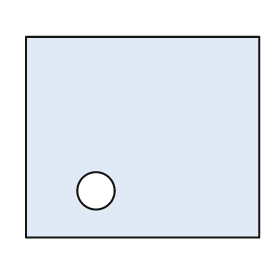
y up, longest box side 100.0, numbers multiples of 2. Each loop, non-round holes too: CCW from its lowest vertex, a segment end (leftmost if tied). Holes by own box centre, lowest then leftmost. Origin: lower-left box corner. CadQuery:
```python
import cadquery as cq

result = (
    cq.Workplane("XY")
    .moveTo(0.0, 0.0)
    .lineTo(100.0, 0.0)
    .lineTo(100.0, 86.0)
    .lineTo(0.0, 86.0)
    .close()
    .moveTo(30.0, 20.0)
    .circle(8.0)
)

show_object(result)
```